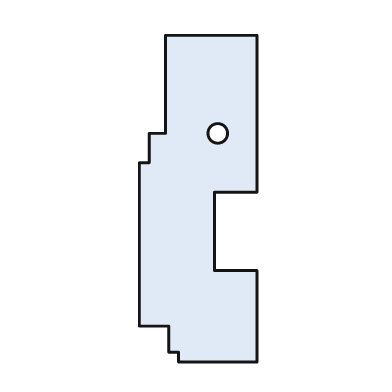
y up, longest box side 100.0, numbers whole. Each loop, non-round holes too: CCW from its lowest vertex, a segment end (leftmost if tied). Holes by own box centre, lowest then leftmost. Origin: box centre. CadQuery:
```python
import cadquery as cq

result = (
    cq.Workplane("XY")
    .moveTo(-6.0, -50.0)
    .lineTo(18.0, -50.0)
    .lineTo(18.0, -22.0)
    .lineTo(5.0, -22.0)
    .lineTo(5.0, 2.0)
    .lineTo(18.0, 2.0)
    .lineTo(18.0, 50.0)
    .lineTo(-10.0, 50.0)
    .lineTo(-10.0, 20.0)
    .lineTo(-15.0, 20.0)
    .lineTo(-15.0, 11.0)
    .lineTo(-18.0, 11.0)
    .lineTo(-18.0, -39.0)
    .lineTo(-9.0, -39.0)
    .lineTo(-9.0, -47.0)
    .lineTo(-6.0, -47.0)
    .close()
    .moveTo(6.0, 20.0)
    .circle(3.0)
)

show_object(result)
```